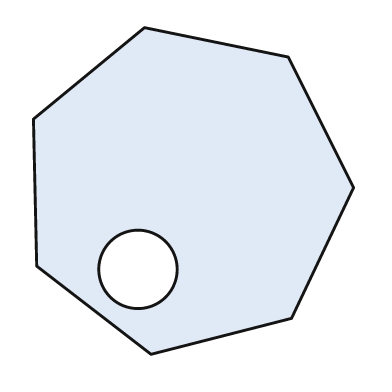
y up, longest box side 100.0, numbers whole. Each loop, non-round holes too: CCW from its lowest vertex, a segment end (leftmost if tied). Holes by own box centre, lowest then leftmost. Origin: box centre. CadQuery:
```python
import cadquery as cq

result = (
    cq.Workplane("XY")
    .moveTo(-13.0, -50.0)
    .lineTo(30.0, -39.0)
    .lineTo(49.0, 1.0)
    .lineTo(29.0, 41.0)
    .lineTo(-15.0, 50.0)
    .lineTo(-49.0, 22.0)
    .lineTo(-48.0, -23.0)
    .close()
    .moveTo(-17.0, -24.0)
    .circle(12.0)
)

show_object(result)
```